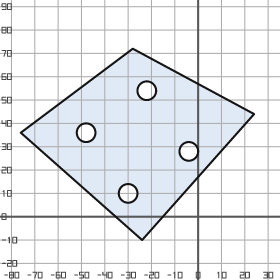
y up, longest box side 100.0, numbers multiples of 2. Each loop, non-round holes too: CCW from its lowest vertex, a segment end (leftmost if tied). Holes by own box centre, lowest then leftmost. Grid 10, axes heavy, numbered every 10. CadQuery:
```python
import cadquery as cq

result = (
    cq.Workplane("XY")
    .moveTo(-24.0, -10.0)
    .lineTo(24.0, 44.0)
    .lineTo(-28.0, 72.0)
    .lineTo(-76.0, 36.0)
    .close()
    .moveTo(-30.0, 10.0)
    .circle(4.0)
    .moveTo(-4.0, 28.0)
    .circle(4.0)
    .moveTo(-48.0, 36.0)
    .circle(4.0)
    .moveTo(-22.0, 54.0)
    .circle(4.0)
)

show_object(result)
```